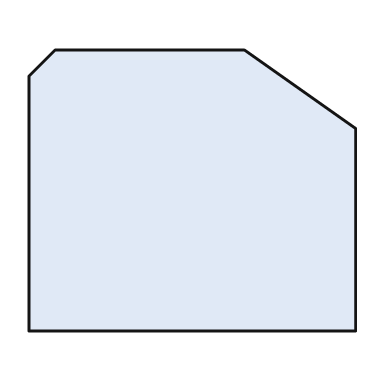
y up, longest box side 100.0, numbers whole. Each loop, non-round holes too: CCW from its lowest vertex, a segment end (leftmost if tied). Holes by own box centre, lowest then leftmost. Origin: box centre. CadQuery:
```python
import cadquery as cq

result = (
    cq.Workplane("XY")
    .moveTo(-50.0, -43.0)
    .lineTo(50.0, -43.0)
    .lineTo(50.0, 19.0)
    .lineTo(16.0, 43.0)
    .lineTo(-42.0, 43.0)
    .lineTo(-50.0, 35.0)
    .close()
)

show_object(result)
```